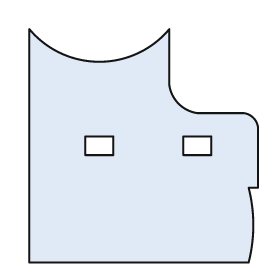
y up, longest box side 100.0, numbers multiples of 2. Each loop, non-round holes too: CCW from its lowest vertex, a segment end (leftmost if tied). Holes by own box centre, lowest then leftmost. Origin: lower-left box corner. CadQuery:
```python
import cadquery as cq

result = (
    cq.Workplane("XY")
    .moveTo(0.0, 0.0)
    .lineTo(94.0, 0.0)
    .threePointArc((96.0, 16.0), (94.0, 32.0))
    .lineTo(98.0, 32.0)
    .lineTo(98.0, 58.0)
    .threePointArc((96.0, 62.0), (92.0, 64.0))
    .lineTo(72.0, 64.0)
    .threePointArc((64.0, 68.0), (60.0, 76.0))
    .lineTo(60.0, 100.0)
    .threePointArc((30.0, 86.0), (0.0, 100.0))
    .close()
    .moveTo(24.0, 46.0)
    .lineTo(36.0, 46.0)
    .lineTo(36.0, 54.0)
    .lineTo(24.0, 54.0)
    .close()
    .moveTo(66.0, 46.0)
    .lineTo(78.0, 46.0)
    .lineTo(78.0, 54.0)
    .lineTo(66.0, 54.0)
    .close()
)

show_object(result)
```